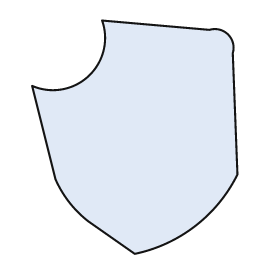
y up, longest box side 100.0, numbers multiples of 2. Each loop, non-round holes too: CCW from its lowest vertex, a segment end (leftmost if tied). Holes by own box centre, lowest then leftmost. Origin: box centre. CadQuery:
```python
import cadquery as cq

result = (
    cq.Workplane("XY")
    .moveTo(0.0, -50.0)
    .threePointArc((26.0, -38.0), (44.0, -16.0))
    .lineTo(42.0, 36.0)
    .threePointArc((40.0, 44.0), (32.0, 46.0))
    .lineTo(-14.0, 50.0)
    .threePointArc((-20.0, 26.0), (-44.0, 22.0))
    .lineTo(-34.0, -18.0)
    .threePointArc((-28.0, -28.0), (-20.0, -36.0))
    .close()
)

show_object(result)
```